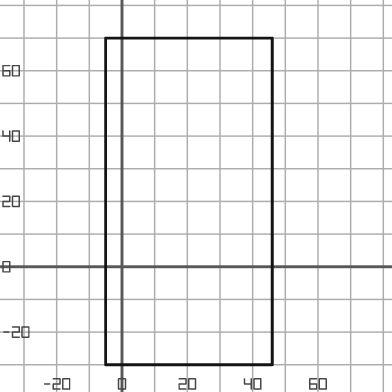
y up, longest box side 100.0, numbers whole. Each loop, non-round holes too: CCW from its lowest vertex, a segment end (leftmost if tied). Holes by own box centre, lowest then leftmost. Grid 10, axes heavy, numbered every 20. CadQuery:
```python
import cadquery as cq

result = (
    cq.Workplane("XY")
    .moveTo(-5.0, -30.0)
    .lineTo(46.0, -30.0)
    .lineTo(46.0, 70.0)
    .lineTo(-5.0, 70.0)
    .close()
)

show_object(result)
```